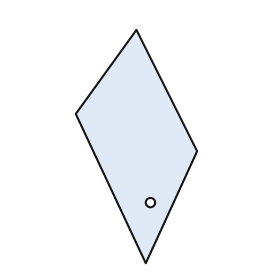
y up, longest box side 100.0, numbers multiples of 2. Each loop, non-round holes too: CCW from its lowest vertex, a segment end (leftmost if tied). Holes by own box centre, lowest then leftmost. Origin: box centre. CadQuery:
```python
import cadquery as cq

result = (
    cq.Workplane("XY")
    .moveTo(4.0, -50.0)
    .lineTo(26.0, -2.0)
    .lineTo(0.0, 50.0)
    .lineTo(-26.0, 14.0)
    .close()
    .moveTo(6.0, -24.0)
    .circle(2.0)
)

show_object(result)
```